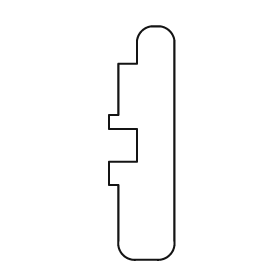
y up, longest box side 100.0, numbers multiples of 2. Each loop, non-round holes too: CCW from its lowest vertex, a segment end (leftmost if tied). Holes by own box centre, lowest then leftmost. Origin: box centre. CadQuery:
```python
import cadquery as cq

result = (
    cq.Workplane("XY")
    .moveTo(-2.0, -50.0)
    .lineTo(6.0, -50.0)
    .threePointArc((12.0, -48.0), (14.0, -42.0))
    .lineTo(14.0, 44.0)
    .threePointArc((12.0, 48.0), (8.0, 50.0))
    .lineTo(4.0, 50.0)
    .threePointArc((0.0, 48.0), (-2.0, 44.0))
    .lineTo(-2.0, 34.0)
    .lineTo(-10.0, 34.0)
    .lineTo(-10.0, 12.0)
    .lineTo(-14.0, 12.0)
    .lineTo(-14.0, 6.0)
    .lineTo(-2.0, 6.0)
    .lineTo(-2.0, -8.0)
    .lineTo(-14.0, -8.0)
    .lineTo(-14.0, -18.0)
    .lineTo(-10.0, -18.0)
    .lineTo(-10.0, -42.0)
    .threePointArc((-8.0, -48.0), (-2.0, -50.0))
    .close()
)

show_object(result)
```